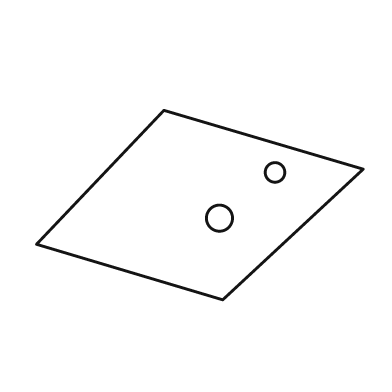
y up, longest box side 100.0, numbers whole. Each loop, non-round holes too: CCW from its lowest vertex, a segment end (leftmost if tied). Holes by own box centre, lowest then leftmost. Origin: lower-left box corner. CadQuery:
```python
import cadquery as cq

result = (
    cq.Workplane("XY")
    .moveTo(57.0, 0.0)
    .lineTo(100.0, 40.0)
    .lineTo(39.0, 58.0)
    .lineTo(0.0, 17.0)
    .close()
    .moveTo(56.0, 25.0)
    .circle(4.0)
    .moveTo(73.0, 39.0)
    .circle(3.0)
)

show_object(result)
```